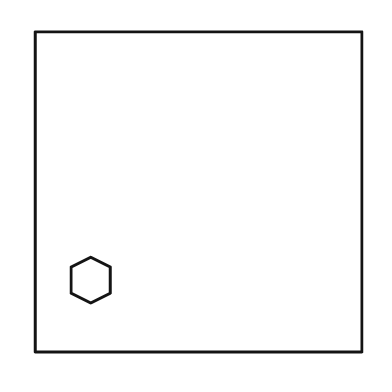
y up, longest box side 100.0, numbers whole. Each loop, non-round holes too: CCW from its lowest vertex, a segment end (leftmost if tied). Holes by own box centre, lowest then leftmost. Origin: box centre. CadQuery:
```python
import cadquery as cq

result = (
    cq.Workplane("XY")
    .moveTo(-50.0, -49.0)
    .lineTo(50.0, -49.0)
    .lineTo(50.0, 49.0)
    .lineTo(-50.0, 49.0)
    .close()
    .moveTo(-33.0, -34.0)
    .lineTo(-27.0, -31.0)
    .lineTo(-27.0, -23.0)
    .lineTo(-33.0, -20.0)
    .lineTo(-39.0, -23.0)
    .lineTo(-39.0, -31.0)
    .close()
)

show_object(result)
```